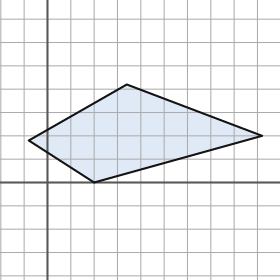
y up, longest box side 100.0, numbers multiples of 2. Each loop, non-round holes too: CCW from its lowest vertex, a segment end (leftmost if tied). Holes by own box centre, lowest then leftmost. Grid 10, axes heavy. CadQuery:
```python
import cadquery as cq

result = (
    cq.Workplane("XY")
    .moveTo(20.0, 0.0)
    .lineTo(92.0, 20.0)
    .lineTo(34.0, 42.0)
    .lineTo(-8.0, 18.0)
    .close()
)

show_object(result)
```